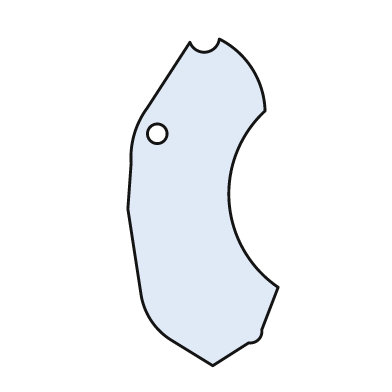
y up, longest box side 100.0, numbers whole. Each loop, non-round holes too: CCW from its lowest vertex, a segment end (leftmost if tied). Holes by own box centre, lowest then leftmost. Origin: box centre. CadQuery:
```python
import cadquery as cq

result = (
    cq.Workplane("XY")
    .moveTo(3.0, -50.0)
    .lineTo(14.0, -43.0)
    .threePointArc((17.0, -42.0), (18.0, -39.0))
    .lineTo(23.0, -26.0)
    .threePointArc((8.0, 0.0), (19.0, 28.0))
    .threePointArc((15.0, 41.0), (5.0, 50.0))
    .threePointArc((1.0, 46.0), (-4.0, 49.0))
    .lineTo(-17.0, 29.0)
    .threePointArc((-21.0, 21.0), (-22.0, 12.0))
    .lineTo(-23.0, -2.0)
    .lineTo(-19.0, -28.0)
    .threePointArc((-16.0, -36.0), (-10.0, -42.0))
    .close()
    .moveTo(-14.0, 21.0)
    .circle(3.0)
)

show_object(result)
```